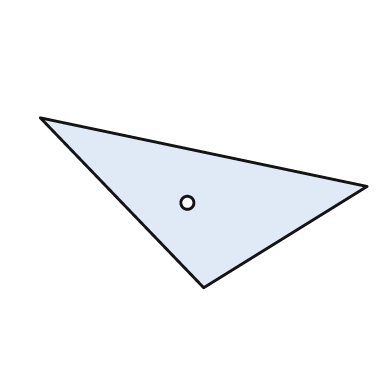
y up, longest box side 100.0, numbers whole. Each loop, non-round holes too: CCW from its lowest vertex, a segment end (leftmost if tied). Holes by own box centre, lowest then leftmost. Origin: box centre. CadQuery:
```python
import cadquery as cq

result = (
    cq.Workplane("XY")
    .moveTo(0.0, -26.0)
    .lineTo(50.0, 5.0)
    .lineTo(-50.0, 26.0)
    .close()
    .moveTo(-5.0, 0.0)
    .circle(2.0)
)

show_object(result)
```